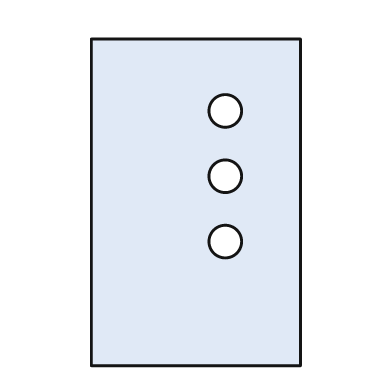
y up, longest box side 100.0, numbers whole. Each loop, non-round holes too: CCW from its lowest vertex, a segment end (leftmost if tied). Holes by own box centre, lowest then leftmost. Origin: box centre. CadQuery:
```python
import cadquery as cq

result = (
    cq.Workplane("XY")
    .moveTo(-32.0, -50.0)
    .lineTo(32.0, -50.0)
    .lineTo(32.0, 50.0)
    .lineTo(-32.0, 50.0)
    .close()
    .moveTo(9.0, -12.0)
    .circle(5.0)
    .moveTo(9.0, 8.0)
    .circle(5.0)
    .moveTo(9.0, 28.0)
    .circle(5.0)
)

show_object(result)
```